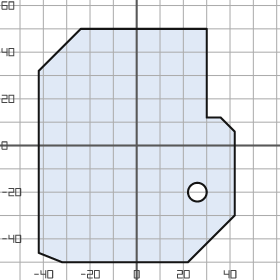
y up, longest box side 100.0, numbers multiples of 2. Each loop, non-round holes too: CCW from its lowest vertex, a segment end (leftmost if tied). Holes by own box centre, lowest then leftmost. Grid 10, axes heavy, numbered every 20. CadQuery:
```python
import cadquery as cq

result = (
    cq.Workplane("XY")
    .moveTo(-32.0, -50.0)
    .lineTo(22.0, -50.0)
    .lineTo(42.0, -30.0)
    .lineTo(42.0, 6.0)
    .lineTo(36.0, 12.0)
    .lineTo(30.0, 12.0)
    .lineTo(30.0, 50.0)
    .lineTo(-24.0, 50.0)
    .lineTo(-42.0, 32.0)
    .lineTo(-42.0, -46.0)
    .close()
    .moveTo(26.0, -20.0)
    .circle(4.0)
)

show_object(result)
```